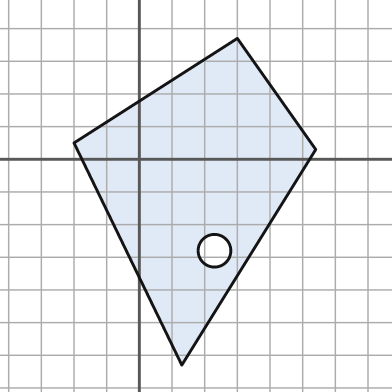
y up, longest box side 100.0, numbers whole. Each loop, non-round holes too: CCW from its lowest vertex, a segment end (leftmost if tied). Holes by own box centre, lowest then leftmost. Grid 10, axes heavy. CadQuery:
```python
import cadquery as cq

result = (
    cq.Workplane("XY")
    .moveTo(13.0, -63.0)
    .lineTo(54.0, 3.0)
    .lineTo(30.0, 37.0)
    .lineTo(-20.0, 5.0)
    .close()
    .moveTo(23.0, -28.0)
    .circle(5.0)
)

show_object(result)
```